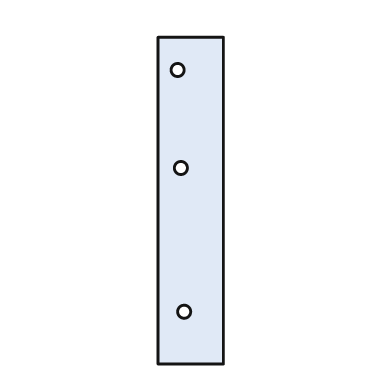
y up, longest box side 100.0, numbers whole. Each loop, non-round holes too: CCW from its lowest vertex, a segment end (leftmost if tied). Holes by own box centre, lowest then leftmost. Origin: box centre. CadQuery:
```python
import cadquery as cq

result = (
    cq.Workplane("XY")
    .moveTo(-10.0, -50.0)
    .lineTo(10.0, -50.0)
    .lineTo(10.0, 50.0)
    .lineTo(-10.0, 50.0)
    .close()
    .moveTo(-2.0, -34.0)
    .circle(2.0)
    .moveTo(-3.0, 10.0)
    .circle(2.0)
    .moveTo(-4.0, 40.0)
    .circle(2.0)
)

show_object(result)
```